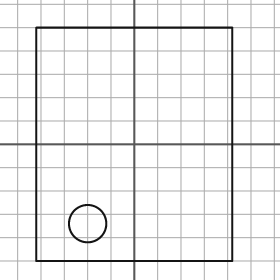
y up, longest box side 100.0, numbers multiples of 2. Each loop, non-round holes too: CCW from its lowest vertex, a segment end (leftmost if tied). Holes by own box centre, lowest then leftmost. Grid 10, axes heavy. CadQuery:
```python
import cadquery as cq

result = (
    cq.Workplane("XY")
    .moveTo(-42.0, -50.0)
    .lineTo(42.0, -50.0)
    .lineTo(42.0, 50.0)
    .lineTo(-42.0, 50.0)
    .close()
    .moveTo(-20.0, -34.0)
    .circle(8.0)
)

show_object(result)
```